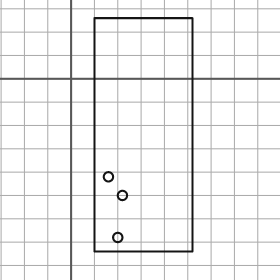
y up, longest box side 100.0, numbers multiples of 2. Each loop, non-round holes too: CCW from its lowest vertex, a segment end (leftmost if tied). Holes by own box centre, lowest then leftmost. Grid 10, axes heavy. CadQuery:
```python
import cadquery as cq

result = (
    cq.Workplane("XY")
    .moveTo(10.0, -74.0)
    .lineTo(52.0, -74.0)
    .lineTo(52.0, 26.0)
    .lineTo(10.0, 26.0)
    .close()
    .moveTo(20.0, -68.0)
    .circle(2.0)
    .moveTo(22.0, -50.0)
    .circle(2.0)
    .moveTo(16.0, -42.0)
    .circle(2.0)
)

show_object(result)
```